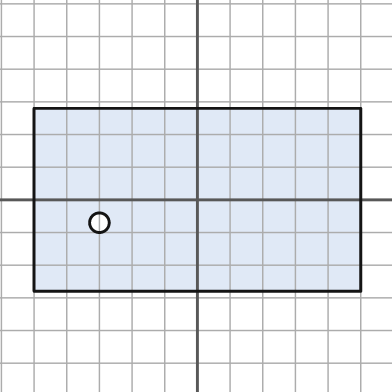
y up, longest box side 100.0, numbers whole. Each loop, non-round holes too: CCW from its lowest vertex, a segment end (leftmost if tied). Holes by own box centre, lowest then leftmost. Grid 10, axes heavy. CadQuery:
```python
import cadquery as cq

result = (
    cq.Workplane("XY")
    .moveTo(-50.0, -28.0)
    .lineTo(50.0, -28.0)
    .lineTo(50.0, 28.0)
    .lineTo(-50.0, 28.0)
    .close()
    .moveTo(-30.0, -7.0)
    .circle(3.0)
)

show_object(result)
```